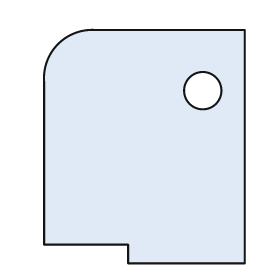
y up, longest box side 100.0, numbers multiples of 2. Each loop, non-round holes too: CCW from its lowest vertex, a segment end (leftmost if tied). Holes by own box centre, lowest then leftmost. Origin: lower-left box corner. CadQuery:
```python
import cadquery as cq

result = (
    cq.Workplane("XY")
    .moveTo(36.0, 0.0)
    .lineTo(86.0, 0.0)
    .lineTo(86.0, 100.0)
    .lineTo(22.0, 100.0)
    .threePointArc((6.0, 94.0), (0.0, 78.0))
    .lineTo(0.0, 8.0)
    .lineTo(36.0, 8.0)
    .close()
    .moveTo(68.0, 74.0)
    .circle(8.0)
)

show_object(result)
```